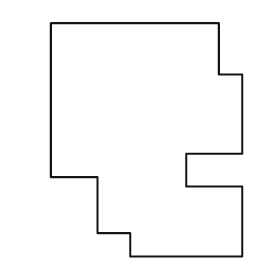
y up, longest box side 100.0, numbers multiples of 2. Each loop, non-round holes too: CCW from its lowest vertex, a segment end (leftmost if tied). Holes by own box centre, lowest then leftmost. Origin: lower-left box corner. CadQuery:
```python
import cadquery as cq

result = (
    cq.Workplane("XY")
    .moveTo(34.0, 0.0)
    .lineTo(82.0, 0.0)
    .lineTo(82.0, 30.0)
    .lineTo(58.0, 30.0)
    .lineTo(58.0, 44.0)
    .lineTo(82.0, 44.0)
    .lineTo(82.0, 78.0)
    .lineTo(72.0, 78.0)
    .lineTo(72.0, 100.0)
    .lineTo(0.0, 100.0)
    .lineTo(0.0, 34.0)
    .lineTo(20.0, 34.0)
    .lineTo(20.0, 10.0)
    .lineTo(34.0, 10.0)
    .close()
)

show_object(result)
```